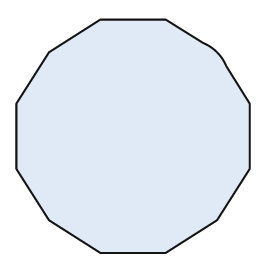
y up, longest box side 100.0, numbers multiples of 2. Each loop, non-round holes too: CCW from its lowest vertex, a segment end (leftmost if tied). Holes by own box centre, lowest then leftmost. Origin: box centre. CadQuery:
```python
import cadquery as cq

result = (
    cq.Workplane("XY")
    .moveTo(-14.0, -50.0)
    .lineTo(14.0, -50.0)
    .lineTo(36.0, -36.0)
    .lineTo(50.0, -14.0)
    .lineTo(50.0, 14.0)
    .lineTo(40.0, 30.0)
    .threePointArc((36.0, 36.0), (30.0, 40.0))
    .lineTo(14.0, 50.0)
    .lineTo(-14.0, 50.0)
    .lineTo(-36.0, 36.0)
    .lineTo(-50.0, 14.0)
    .lineTo(-50.0, -14.0)
    .lineTo(-36.0, -36.0)
    .close()
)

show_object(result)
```